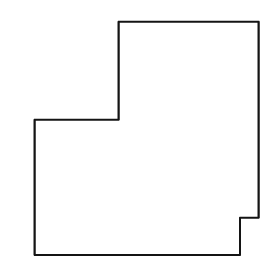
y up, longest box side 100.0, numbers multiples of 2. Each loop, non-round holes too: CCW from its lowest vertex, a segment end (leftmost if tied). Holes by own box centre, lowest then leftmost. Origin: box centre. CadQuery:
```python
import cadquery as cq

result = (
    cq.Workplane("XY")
    .moveTo(-48.0, -50.0)
    .lineTo(40.0, -50.0)
    .lineTo(40.0, -34.0)
    .lineTo(48.0, -34.0)
    .lineTo(48.0, 50.0)
    .lineTo(-12.0, 50.0)
    .lineTo(-12.0, 8.0)
    .lineTo(-48.0, 8.0)
    .close()
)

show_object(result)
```